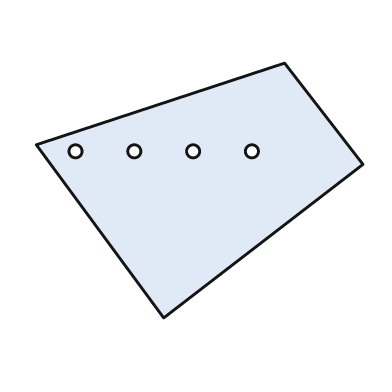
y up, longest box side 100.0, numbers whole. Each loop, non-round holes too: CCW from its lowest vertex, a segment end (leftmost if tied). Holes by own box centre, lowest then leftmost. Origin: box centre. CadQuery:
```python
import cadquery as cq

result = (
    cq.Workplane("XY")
    .moveTo(-11.0, -39.0)
    .lineTo(50.0, 8.0)
    .lineTo(26.0, 39.0)
    .lineTo(-50.0, 14.0)
    .close()
    .moveTo(-38.0, 12.0)
    .circle(2.0)
    .moveTo(-20.0, 12.0)
    .circle(2.0)
    .moveTo(-2.0, 12.0)
    .circle(2.0)
    .moveTo(16.0, 12.0)
    .circle(2.0)
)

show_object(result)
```